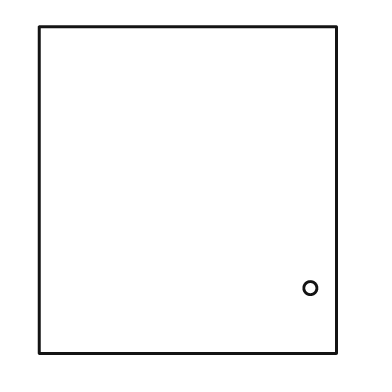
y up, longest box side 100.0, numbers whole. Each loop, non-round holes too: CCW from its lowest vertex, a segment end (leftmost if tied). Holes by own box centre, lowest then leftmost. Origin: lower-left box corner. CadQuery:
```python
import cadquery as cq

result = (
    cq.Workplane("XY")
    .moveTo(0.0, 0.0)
    .lineTo(91.0, 0.0)
    .lineTo(91.0, 100.0)
    .lineTo(0.0, 100.0)
    .close()
    .moveTo(83.0, 20.0)
    .circle(2.0)
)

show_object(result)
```